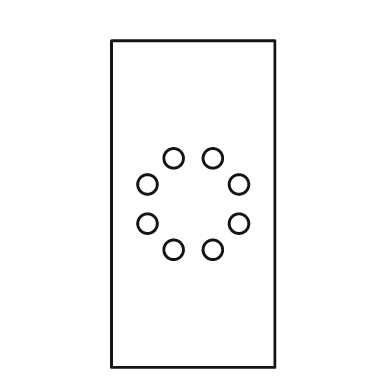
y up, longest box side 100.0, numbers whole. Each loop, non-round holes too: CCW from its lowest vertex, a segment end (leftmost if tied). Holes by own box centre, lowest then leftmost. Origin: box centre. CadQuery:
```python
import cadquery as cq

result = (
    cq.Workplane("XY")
    .moveTo(-25.0, -50.0)
    .lineTo(25.0, -50.0)
    .lineTo(25.0, 50.0)
    .lineTo(-25.0, 50.0)
    .close()
    .moveTo(-6.0, -14.0)
    .circle(3.0)
    .moveTo(6.0, -14.0)
    .circle(3.0)
    .moveTo(-14.0, -6.0)
    .circle(3.0)
    .moveTo(14.0, -6.0)
    .circle(3.0)
    .moveTo(-14.0, 6.0)
    .circle(3.0)
    .moveTo(14.0, 6.0)
    .circle(3.0)
    .moveTo(-6.0, 14.0)
    .circle(3.0)
    .moveTo(6.0, 14.0)
    .circle(3.0)
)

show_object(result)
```